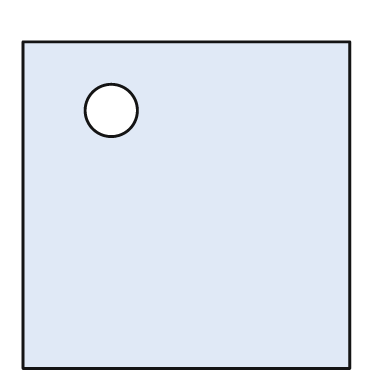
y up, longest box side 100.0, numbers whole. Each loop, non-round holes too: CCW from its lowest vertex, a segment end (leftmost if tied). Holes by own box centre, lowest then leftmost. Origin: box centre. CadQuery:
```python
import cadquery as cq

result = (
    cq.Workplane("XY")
    .moveTo(-50.0, -50.0)
    .lineTo(50.0, -50.0)
    .lineTo(50.0, 50.0)
    .lineTo(-50.0, 50.0)
    .close()
    .moveTo(-23.0, 29.0)
    .circle(8.0)
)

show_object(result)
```